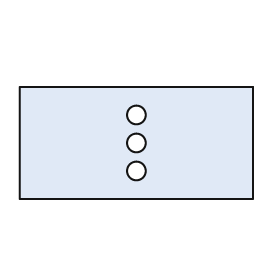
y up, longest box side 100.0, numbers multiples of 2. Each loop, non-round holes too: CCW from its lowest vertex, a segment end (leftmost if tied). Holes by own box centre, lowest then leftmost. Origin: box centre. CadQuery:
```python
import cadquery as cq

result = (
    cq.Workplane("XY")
    .moveTo(-50.0, -24.0)
    .lineTo(50.0, -24.0)
    .lineTo(50.0, 24.0)
    .lineTo(-50.0, 24.0)
    .close()
    .moveTo(0.0, -12.0)
    .circle(4.0)
    .moveTo(0.0, 0.0)
    .circle(4.0)
    .moveTo(0.0, 12.0)
    .circle(4.0)
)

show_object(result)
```